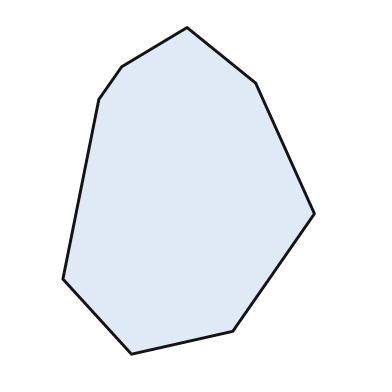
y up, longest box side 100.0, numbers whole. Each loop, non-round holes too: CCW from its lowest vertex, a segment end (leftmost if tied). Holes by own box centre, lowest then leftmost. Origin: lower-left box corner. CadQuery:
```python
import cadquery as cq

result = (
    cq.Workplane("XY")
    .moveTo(21.0, 0.0)
    .lineTo(52.0, 7.0)
    .lineTo(77.0, 43.0)
    .lineTo(59.0, 83.0)
    .lineTo(38.0, 100.0)
    .lineTo(18.0, 88.0)
    .lineTo(11.0, 78.0)
    .lineTo(0.0, 23.0)
    .close()
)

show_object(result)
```